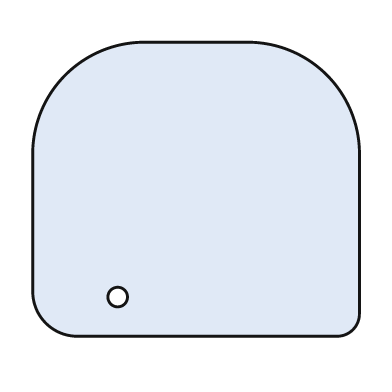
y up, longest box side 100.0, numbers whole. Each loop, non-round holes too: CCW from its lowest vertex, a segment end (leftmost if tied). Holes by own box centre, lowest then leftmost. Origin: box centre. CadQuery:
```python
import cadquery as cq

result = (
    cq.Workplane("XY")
    .moveTo(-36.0, -45.0)
    .lineTo(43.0, -45.0)
    .threePointArc((48.0, -43.0), (50.0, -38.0))
    .lineTo(50.0, 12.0)
    .threePointArc((40.0, 35.0), (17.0, 45.0))
    .lineTo(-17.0, 45.0)
    .threePointArc((-40.0, 35.0), (-50.0, 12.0))
    .lineTo(-50.0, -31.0)
    .threePointArc((-46.0, -41.0), (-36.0, -45.0))
    .close()
    .moveTo(-24.0, -33.0)
    .circle(3.0)
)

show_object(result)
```